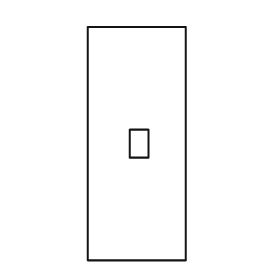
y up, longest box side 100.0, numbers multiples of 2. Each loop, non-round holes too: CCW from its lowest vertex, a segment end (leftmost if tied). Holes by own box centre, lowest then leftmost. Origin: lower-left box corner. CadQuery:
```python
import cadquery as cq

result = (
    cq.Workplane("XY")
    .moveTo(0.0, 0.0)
    .lineTo(42.0, 0.0)
    .lineTo(42.0, 100.0)
    .lineTo(0.0, 100.0)
    .close()
    .moveTo(18.0, 44.0)
    .lineTo(26.0, 44.0)
    .lineTo(26.0, 56.0)
    .lineTo(18.0, 56.0)
    .close()
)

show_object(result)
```